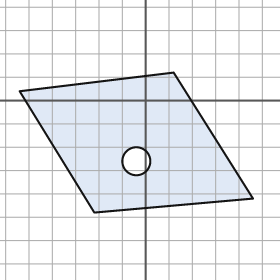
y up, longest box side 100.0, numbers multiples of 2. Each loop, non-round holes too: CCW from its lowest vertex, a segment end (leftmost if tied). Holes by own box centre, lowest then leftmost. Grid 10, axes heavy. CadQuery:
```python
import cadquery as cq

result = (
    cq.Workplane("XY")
    .moveTo(-22.0, -48.0)
    .lineTo(46.0, -42.0)
    .lineTo(12.0, 12.0)
    .lineTo(-54.0, 4.0)
    .close()
    .moveTo(-4.0, -26.0)
    .circle(6.0)
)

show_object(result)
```